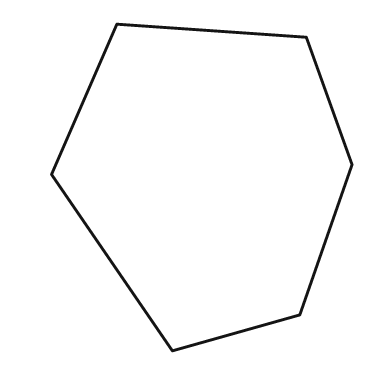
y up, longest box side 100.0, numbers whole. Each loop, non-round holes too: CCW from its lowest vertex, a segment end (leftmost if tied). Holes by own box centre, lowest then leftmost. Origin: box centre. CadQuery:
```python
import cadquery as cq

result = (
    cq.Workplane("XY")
    .moveTo(-9.0, -50.0)
    .lineTo(30.0, -39.0)
    .lineTo(46.0, 7.0)
    .lineTo(32.0, 46.0)
    .lineTo(-26.0, 50.0)
    .lineTo(-46.0, 4.0)
    .close()
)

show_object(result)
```